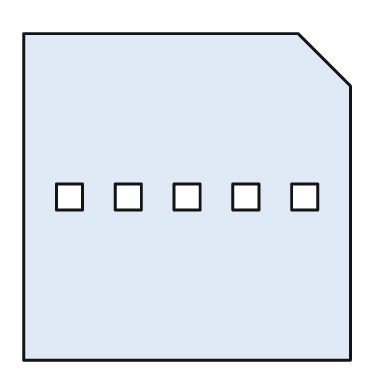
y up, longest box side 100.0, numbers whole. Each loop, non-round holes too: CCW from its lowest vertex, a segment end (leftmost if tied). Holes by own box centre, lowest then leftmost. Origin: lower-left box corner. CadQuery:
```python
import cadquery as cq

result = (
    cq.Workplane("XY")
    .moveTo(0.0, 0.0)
    .lineTo(100.0, 0.0)
    .lineTo(100.0, 84.0)
    .lineTo(84.0, 100.0)
    .lineTo(0.0, 100.0)
    .close()
    .moveTo(10.0, 46.0)
    .lineTo(18.0, 46.0)
    .lineTo(18.0, 54.0)
    .lineTo(10.0, 54.0)
    .close()
    .moveTo(28.0, 46.0)
    .lineTo(36.0, 46.0)
    .lineTo(36.0, 54.0)
    .lineTo(28.0, 54.0)
    .close()
    .moveTo(46.0, 46.0)
    .lineTo(54.0, 46.0)
    .lineTo(54.0, 54.0)
    .lineTo(46.0, 54.0)
    .close()
    .moveTo(64.0, 46.0)
    .lineTo(72.0, 46.0)
    .lineTo(72.0, 54.0)
    .lineTo(64.0, 54.0)
    .close()
    .moveTo(82.0, 46.0)
    .lineTo(90.0, 46.0)
    .lineTo(90.0, 54.0)
    .lineTo(82.0, 54.0)
    .close()
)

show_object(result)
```